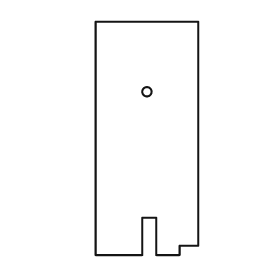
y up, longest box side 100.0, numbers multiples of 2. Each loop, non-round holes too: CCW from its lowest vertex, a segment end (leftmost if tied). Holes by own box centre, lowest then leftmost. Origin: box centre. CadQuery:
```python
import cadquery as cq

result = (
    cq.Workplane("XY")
    .moveTo(-22.0, -50.0)
    .lineTo(-2.0, -50.0)
    .lineTo(-2.0, -34.0)
    .lineTo(4.0, -34.0)
    .lineTo(4.0, -50.0)
    .lineTo(14.0, -50.0)
    .lineTo(14.0, -46.0)
    .lineTo(22.0, -46.0)
    .lineTo(22.0, 50.0)
    .lineTo(-22.0, 50.0)
    .close()
    .moveTo(0.0, 20.0)
    .circle(2.0)
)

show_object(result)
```